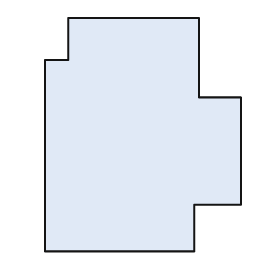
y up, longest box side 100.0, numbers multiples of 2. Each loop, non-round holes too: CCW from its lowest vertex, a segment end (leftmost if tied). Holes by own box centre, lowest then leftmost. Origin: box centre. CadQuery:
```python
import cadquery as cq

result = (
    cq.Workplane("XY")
    .moveTo(-42.0, -50.0)
    .lineTo(22.0, -50.0)
    .lineTo(22.0, -30.0)
    .lineTo(42.0, -30.0)
    .lineTo(42.0, 16.0)
    .lineTo(24.0, 16.0)
    .lineTo(24.0, 50.0)
    .lineTo(-32.0, 50.0)
    .lineTo(-32.0, 32.0)
    .lineTo(-42.0, 32.0)
    .close()
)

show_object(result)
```